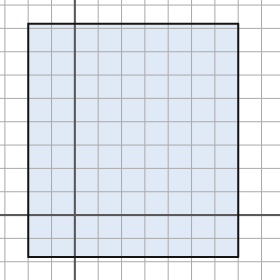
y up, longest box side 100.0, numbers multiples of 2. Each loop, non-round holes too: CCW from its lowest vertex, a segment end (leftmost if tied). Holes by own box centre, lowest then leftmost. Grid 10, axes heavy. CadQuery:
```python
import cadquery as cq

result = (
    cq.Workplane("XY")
    .moveTo(-20.0, -18.0)
    .lineTo(70.0, -18.0)
    .lineTo(70.0, 82.0)
    .lineTo(-20.0, 82.0)
    .close()
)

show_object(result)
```